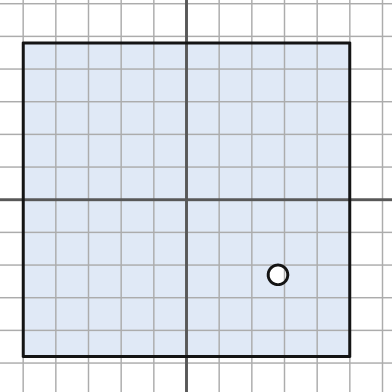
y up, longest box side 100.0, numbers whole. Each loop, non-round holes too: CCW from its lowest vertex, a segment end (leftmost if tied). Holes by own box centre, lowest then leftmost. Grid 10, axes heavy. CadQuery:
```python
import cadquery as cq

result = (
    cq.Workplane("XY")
    .moveTo(-50.0, -48.0)
    .lineTo(50.0, -48.0)
    .lineTo(50.0, 48.0)
    .lineTo(-50.0, 48.0)
    .close()
    .moveTo(28.0, -23.0)
    .circle(3.0)
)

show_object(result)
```